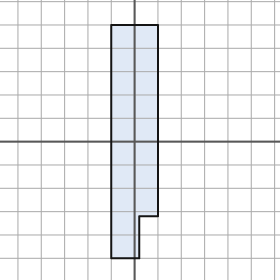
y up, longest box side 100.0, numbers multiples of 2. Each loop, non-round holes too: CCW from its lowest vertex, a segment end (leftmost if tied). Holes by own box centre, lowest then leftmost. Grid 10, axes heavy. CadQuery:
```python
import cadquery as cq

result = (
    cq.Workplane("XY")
    .moveTo(-10.0, -50.0)
    .lineTo(2.0, -50.0)
    .lineTo(2.0, -32.0)
    .lineTo(10.0, -32.0)
    .lineTo(10.0, 50.0)
    .lineTo(-10.0, 50.0)
    .close()
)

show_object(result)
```